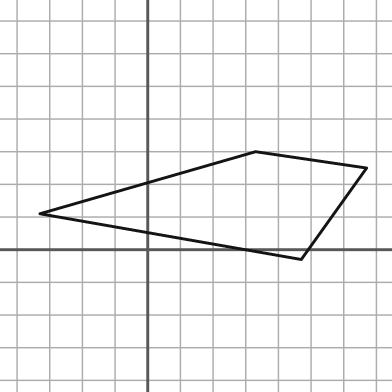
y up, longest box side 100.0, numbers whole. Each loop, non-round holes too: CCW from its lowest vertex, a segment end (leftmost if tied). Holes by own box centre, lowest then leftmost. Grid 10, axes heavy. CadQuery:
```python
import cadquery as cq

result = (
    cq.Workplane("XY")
    .moveTo(47.0, -3.0)
    .lineTo(67.0, 25.0)
    .lineTo(33.0, 30.0)
    .lineTo(-33.0, 11.0)
    .close()
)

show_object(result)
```